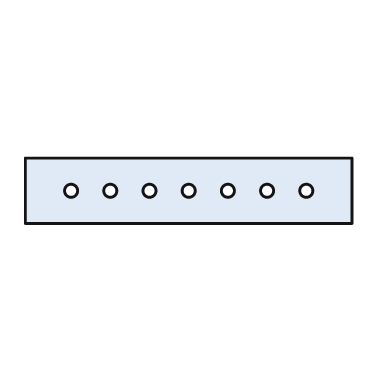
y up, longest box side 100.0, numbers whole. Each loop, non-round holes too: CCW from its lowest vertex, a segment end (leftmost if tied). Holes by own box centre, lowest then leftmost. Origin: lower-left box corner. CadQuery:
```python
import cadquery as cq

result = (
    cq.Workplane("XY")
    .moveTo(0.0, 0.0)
    .lineTo(100.0, 0.0)
    .lineTo(100.0, 20.0)
    .lineTo(0.0, 20.0)
    .close()
    .moveTo(14.0, 10.0)
    .circle(2.0)
    .moveTo(26.0, 10.0)
    .circle(2.0)
    .moveTo(38.0, 10.0)
    .circle(2.0)
    .moveTo(50.0, 10.0)
    .circle(2.0)
    .moveTo(62.0, 10.0)
    .circle(2.0)
    .moveTo(74.0, 10.0)
    .circle(2.0)
    .moveTo(86.0, 10.0)
    .circle(2.0)
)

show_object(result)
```